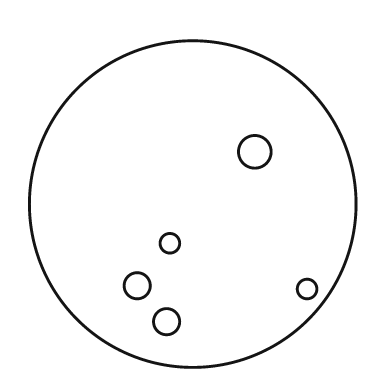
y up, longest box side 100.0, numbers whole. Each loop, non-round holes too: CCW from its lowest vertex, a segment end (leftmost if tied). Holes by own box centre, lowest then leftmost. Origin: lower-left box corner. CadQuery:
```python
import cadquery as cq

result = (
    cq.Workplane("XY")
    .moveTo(50.0, 50.0)
    .circle(50.0)
    .moveTo(42.0, 14.0)
    .circle(4.0)
    .moveTo(85.0, 24.0)
    .circle(3.0)
    .moveTo(33.0, 25.0)
    .circle(4.0)
    .moveTo(43.0, 38.0)
    .circle(3.0)
    .moveTo(69.0, 66.0)
    .circle(5.0)
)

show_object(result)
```